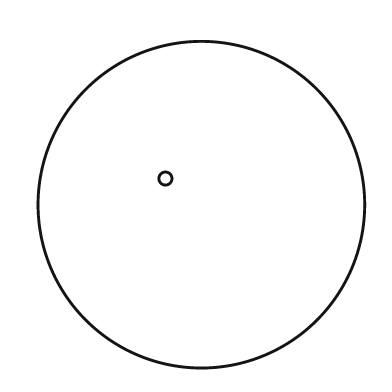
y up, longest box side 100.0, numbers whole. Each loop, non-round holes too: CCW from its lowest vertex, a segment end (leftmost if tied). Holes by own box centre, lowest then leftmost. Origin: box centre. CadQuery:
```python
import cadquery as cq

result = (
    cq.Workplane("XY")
    .moveTo(0.0, 0.0)
    .circle(50.0)
    .moveTo(-11.0, 8.0)
    .circle(2.0)
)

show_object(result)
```